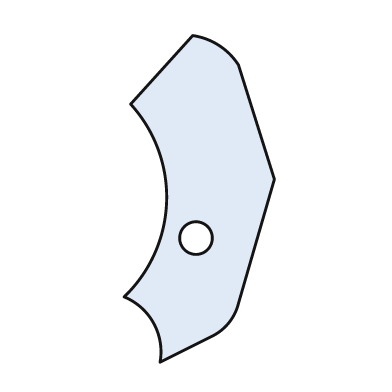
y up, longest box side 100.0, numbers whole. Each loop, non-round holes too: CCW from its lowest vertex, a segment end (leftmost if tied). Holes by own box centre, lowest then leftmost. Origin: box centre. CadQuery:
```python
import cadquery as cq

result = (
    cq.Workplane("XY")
    .moveTo(-12.0, -50.0)
    .lineTo(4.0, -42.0)
    .threePointArc((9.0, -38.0), (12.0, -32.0))
    .lineTo(23.0, 6.0)
    .lineTo(12.0, 41.0)
    .threePointArc((6.0, 47.0), (-2.0, 50.0))
    .lineTo(-21.0, 29.0)
    .threePointArc((-10.0, -1.0), (-23.0, -30.0))
    .threePointArc((-14.0, -38.0), (-12.0, -50.0))
    .close()
    .moveTo(-1.0, -12.0)
    .circle(5.0)
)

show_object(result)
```